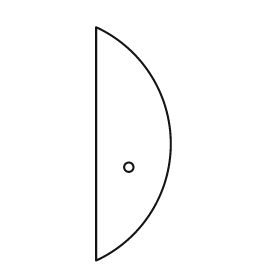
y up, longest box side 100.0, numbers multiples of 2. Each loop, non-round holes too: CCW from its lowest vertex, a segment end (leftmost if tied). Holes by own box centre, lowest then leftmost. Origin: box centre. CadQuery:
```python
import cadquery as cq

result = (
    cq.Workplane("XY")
    .moveTo(-16.0, -50.0)
    .threePointArc((16.0, 0.0), (-16.0, 50.0))
    .close()
    .moveTo(-2.0, -10.0)
    .circle(2.0)
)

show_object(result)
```